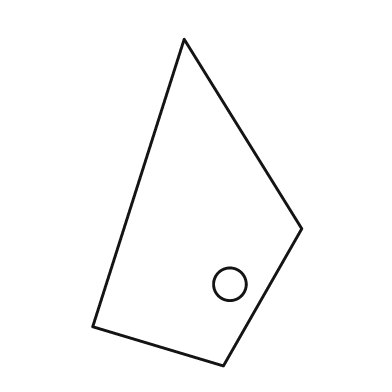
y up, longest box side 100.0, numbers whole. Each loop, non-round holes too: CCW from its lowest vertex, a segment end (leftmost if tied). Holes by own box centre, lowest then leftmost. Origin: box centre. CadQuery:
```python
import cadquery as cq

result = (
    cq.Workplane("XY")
    .moveTo(8.0, -50.0)
    .lineTo(32.0, -8.0)
    .lineTo(-4.0, 50.0)
    .lineTo(-32.0, -38.0)
    .close()
    .moveTo(10.0, -25.0)
    .circle(5.0)
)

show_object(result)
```